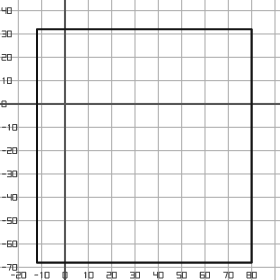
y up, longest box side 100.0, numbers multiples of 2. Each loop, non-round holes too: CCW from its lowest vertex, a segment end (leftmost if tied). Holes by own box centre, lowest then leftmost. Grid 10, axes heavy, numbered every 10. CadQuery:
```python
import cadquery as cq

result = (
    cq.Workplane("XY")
    .moveTo(-12.0, -68.0)
    .lineTo(80.0, -68.0)
    .lineTo(80.0, 32.0)
    .lineTo(-12.0, 32.0)
    .close()
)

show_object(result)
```